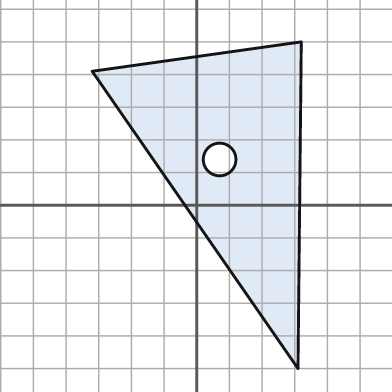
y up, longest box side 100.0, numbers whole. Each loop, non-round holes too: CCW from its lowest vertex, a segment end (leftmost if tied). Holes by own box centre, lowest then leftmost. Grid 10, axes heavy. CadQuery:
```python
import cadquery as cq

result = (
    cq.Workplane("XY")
    .moveTo(31.0, -50.0)
    .lineTo(32.0, 50.0)
    .lineTo(-32.0, 41.0)
    .close()
    .moveTo(7.0, 14.0)
    .circle(5.0)
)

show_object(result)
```